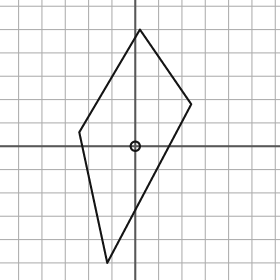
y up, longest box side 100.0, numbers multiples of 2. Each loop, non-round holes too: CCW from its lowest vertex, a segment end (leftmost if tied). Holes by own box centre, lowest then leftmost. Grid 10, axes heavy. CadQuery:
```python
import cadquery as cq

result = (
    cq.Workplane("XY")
    .moveTo(-12.0, -50.0)
    .lineTo(24.0, 18.0)
    .lineTo(2.0, 50.0)
    .lineTo(-24.0, 6.0)
    .close()
    .moveTo(0.0, 0.0)
    .circle(2.0)
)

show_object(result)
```